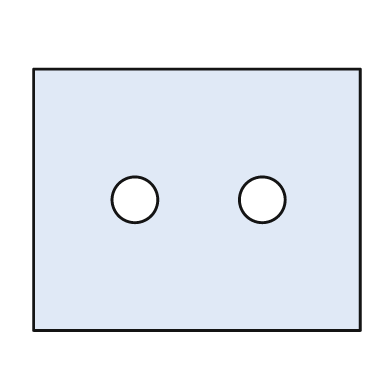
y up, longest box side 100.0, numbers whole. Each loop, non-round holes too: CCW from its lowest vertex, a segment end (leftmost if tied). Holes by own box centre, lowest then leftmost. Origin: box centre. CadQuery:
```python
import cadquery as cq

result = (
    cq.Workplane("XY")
    .moveTo(-50.0, -40.0)
    .lineTo(50.0, -40.0)
    .lineTo(50.0, 40.0)
    .lineTo(-50.0, 40.0)
    .close()
    .moveTo(-19.0, 0.0)
    .circle(7.0)
    .moveTo(20.0, 0.0)
    .circle(7.0)
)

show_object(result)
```